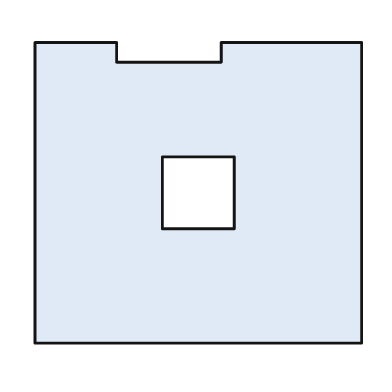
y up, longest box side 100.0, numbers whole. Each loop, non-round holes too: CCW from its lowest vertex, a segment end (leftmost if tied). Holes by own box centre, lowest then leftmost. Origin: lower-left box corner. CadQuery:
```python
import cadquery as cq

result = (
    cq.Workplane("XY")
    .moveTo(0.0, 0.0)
    .lineTo(100.0, 0.0)
    .lineTo(100.0, 92.0)
    .lineTo(57.0, 92.0)
    .lineTo(57.0, 86.0)
    .lineTo(25.0, 86.0)
    .lineTo(25.0, 92.0)
    .lineTo(0.0, 92.0)
    .close()
    .moveTo(39.0, 35.0)
    .lineTo(61.0, 35.0)
    .lineTo(61.0, 57.0)
    .lineTo(39.0, 57.0)
    .close()
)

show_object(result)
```